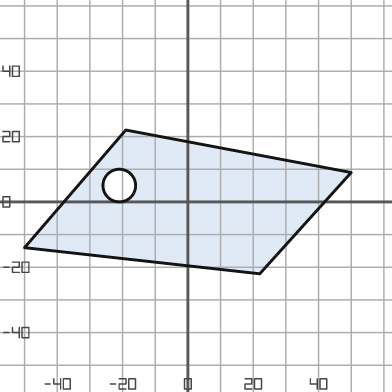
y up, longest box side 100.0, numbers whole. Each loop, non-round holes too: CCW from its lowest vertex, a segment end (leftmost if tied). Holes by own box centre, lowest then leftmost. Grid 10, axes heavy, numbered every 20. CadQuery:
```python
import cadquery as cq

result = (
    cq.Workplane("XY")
    .moveTo(22.0, -22.0)
    .lineTo(50.0, 9.0)
    .lineTo(-19.0, 22.0)
    .lineTo(-50.0, -14.0)
    .close()
    .moveTo(-21.0, 5.0)
    .circle(5.0)
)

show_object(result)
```